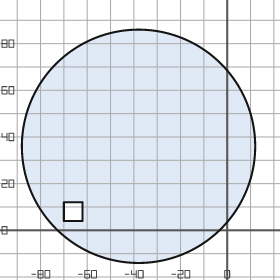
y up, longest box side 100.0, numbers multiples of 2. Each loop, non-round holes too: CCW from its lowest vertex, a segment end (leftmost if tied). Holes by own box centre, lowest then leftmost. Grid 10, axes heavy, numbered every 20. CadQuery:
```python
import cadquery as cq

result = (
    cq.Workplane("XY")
    .moveTo(-38.0, 36.0)
    .circle(50.0)
    .moveTo(-70.0, 4.0)
    .lineTo(-62.0, 4.0)
    .lineTo(-62.0, 12.0)
    .lineTo(-70.0, 12.0)
    .close()
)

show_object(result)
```